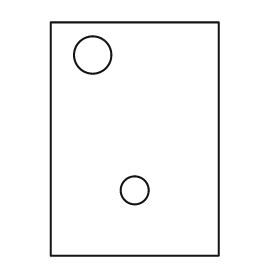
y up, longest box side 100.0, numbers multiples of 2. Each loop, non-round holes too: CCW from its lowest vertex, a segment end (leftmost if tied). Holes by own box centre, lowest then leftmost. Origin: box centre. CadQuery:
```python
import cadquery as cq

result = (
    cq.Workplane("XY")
    .moveTo(-36.0, -50.0)
    .lineTo(36.0, -50.0)
    .lineTo(36.0, 50.0)
    .lineTo(-36.0, 50.0)
    .close()
    .moveTo(0.0, -22.0)
    .circle(6.0)
    .moveTo(-18.0, 36.0)
    .circle(8.0)
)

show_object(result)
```